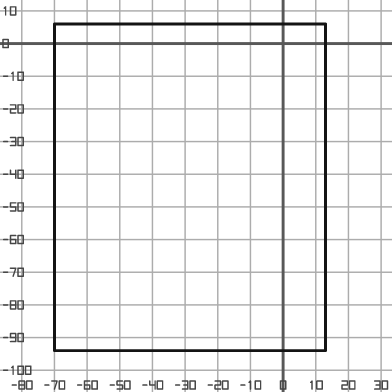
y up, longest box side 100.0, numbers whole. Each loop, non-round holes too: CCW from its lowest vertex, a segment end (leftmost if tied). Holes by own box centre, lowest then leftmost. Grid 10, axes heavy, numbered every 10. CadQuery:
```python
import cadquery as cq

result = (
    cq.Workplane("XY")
    .moveTo(-70.0, -94.0)
    .lineTo(13.0, -94.0)
    .lineTo(13.0, 6.0)
    .lineTo(-70.0, 6.0)
    .close()
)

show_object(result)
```